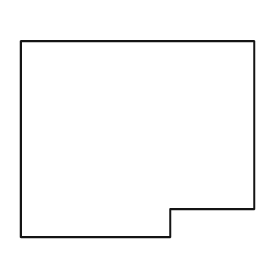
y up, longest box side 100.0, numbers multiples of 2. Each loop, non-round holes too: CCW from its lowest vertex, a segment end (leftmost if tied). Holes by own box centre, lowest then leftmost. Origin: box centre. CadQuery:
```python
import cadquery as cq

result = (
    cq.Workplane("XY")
    .moveTo(-50.0, -42.0)
    .lineTo(14.0, -42.0)
    .lineTo(14.0, -30.0)
    .lineTo(50.0, -30.0)
    .lineTo(50.0, 42.0)
    .lineTo(-50.0, 42.0)
    .close()
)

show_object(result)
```